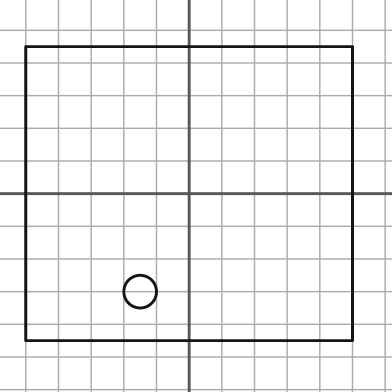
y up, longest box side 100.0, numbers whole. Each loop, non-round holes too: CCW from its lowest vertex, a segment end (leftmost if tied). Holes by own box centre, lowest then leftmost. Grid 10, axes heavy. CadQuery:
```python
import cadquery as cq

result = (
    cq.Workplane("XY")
    .moveTo(-50.0, -45.0)
    .lineTo(50.0, -45.0)
    .lineTo(50.0, 45.0)
    .lineTo(-50.0, 45.0)
    .close()
    .moveTo(-15.0, -30.0)
    .circle(5.0)
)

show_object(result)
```